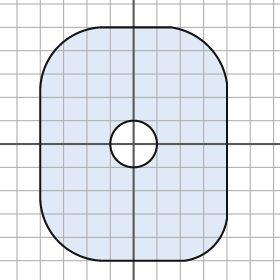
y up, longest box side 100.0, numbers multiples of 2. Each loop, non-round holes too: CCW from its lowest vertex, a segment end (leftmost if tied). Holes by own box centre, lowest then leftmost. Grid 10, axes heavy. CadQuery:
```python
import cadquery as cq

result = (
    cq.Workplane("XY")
    .moveTo(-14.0, -50.0)
    .lineTo(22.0, -50.0)
    .threePointArc((34.0, -44.0), (40.0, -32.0))
    .lineTo(40.0, 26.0)
    .threePointArc((32.0, 42.0), (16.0, 50.0))
    .lineTo(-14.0, 50.0)
    .threePointArc((-32.0, 42.0), (-40.0, 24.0))
    .lineTo(-40.0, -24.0)
    .threePointArc((-32.0, -42.0), (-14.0, -50.0))
    .close()
    .moveTo(0.0, 0.0)
    .circle(10.0)
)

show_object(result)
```